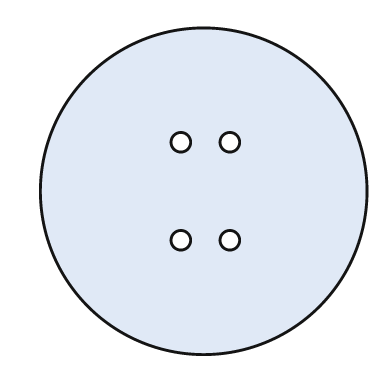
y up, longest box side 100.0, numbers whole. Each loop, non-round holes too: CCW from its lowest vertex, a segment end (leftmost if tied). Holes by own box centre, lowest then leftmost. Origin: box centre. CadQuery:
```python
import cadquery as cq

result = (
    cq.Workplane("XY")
    .moveTo(0.0, 0.0)
    .circle(50.0)
    .moveTo(-7.0, -15.0)
    .circle(3.0)
    .moveTo(8.0, -15.0)
    .circle(3.0)
    .moveTo(-7.0, 15.0)
    .circle(3.0)
    .moveTo(8.0, 15.0)
    .circle(3.0)
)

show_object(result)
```